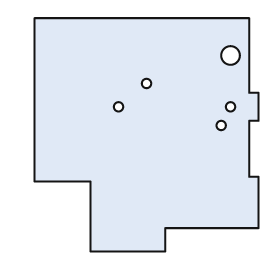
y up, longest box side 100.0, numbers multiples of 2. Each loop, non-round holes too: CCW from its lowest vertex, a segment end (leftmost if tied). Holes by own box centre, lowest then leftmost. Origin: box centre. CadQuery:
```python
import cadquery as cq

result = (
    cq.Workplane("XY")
    .moveTo(-24.0, -50.0)
    .lineTo(8.0, -50.0)
    .lineTo(8.0, -40.0)
    .lineTo(48.0, -40.0)
    .lineTo(48.0, -18.0)
    .lineTo(44.0, -18.0)
    .lineTo(44.0, 6.0)
    .lineTo(48.0, 6.0)
    .lineTo(48.0, 18.0)
    .lineTo(44.0, 18.0)
    .lineTo(44.0, 50.0)
    .lineTo(-48.0, 50.0)
    .lineTo(-48.0, -20.0)
    .lineTo(-24.0, -20.0)
    .close()
    .moveTo(32.0, 4.0)
    .circle(2.0)
    .moveTo(-12.0, 12.0)
    .circle(2.0)
    .moveTo(36.0, 12.0)
    .circle(2.0)
    .moveTo(0.0, 22.0)
    .circle(2.0)
    .moveTo(36.0, 34.0)
    .circle(4.0)
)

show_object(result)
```